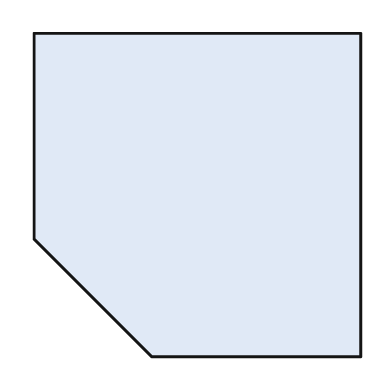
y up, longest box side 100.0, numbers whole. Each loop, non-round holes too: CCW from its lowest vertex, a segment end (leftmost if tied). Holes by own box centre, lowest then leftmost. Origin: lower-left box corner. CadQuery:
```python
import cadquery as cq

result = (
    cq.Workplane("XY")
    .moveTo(36.0, 0.0)
    .lineTo(100.0, 0.0)
    .lineTo(100.0, 99.0)
    .lineTo(0.0, 99.0)
    .lineTo(0.0, 36.0)
    .close()
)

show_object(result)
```